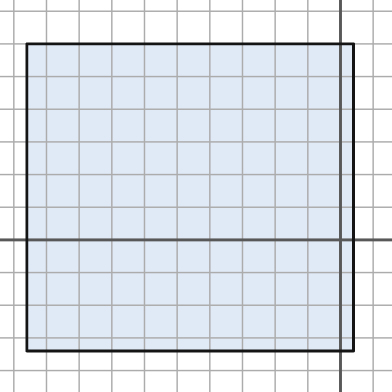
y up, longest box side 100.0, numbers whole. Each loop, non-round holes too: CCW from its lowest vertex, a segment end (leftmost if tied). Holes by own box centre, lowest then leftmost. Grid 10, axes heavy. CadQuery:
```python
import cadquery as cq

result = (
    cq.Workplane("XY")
    .moveTo(-96.0, -34.0)
    .lineTo(4.0, -34.0)
    .lineTo(4.0, 60.0)
    .lineTo(-96.0, 60.0)
    .close()
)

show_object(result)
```